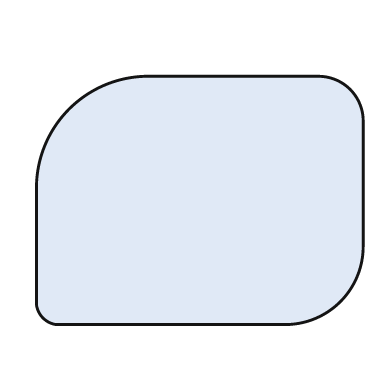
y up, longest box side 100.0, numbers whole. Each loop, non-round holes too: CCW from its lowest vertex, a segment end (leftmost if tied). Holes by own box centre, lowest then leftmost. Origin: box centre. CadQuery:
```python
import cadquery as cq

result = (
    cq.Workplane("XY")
    .moveTo(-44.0, -38.0)
    .lineTo(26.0, -38.0)
    .threePointArc((43.0, -31.0), (50.0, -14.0))
    .lineTo(50.0, 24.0)
    .threePointArc((46.0, 34.0), (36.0, 38.0))
    .lineTo(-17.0, 38.0)
    .threePointArc((-40.0, 28.0), (-50.0, 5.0))
    .lineTo(-50.0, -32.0)
    .threePointArc((-48.0, -36.0), (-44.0, -38.0))
    .close()
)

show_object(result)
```